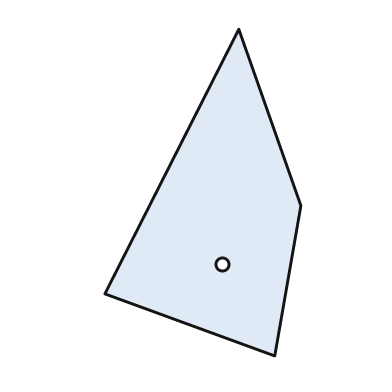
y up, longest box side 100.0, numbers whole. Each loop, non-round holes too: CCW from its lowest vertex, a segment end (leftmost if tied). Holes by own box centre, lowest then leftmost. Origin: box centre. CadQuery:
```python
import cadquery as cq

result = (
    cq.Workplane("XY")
    .moveTo(22.0, -50.0)
    .lineTo(30.0, -4.0)
    .lineTo(11.0, 50.0)
    .lineTo(-30.0, -31.0)
    .close()
    .moveTo(6.0, -22.0)
    .circle(2.0)
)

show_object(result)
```